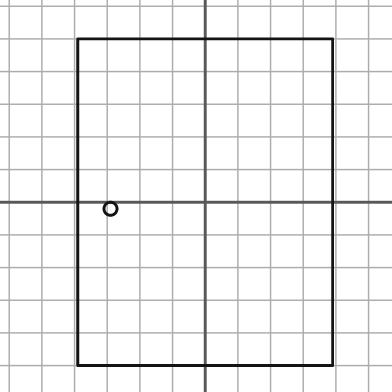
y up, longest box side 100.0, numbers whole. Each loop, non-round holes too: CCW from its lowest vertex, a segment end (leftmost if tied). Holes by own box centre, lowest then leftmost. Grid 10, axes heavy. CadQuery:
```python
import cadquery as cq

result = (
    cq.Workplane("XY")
    .moveTo(-39.0, -50.0)
    .lineTo(39.0, -50.0)
    .lineTo(39.0, 50.0)
    .lineTo(-39.0, 50.0)
    .close()
    .moveTo(-29.0, -2.0)
    .circle(2.0)
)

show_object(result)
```